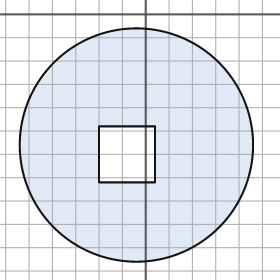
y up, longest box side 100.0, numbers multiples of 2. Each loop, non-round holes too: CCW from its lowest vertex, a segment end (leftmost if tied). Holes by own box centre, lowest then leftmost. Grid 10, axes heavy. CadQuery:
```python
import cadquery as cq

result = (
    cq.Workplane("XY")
    .moveTo(-4.0, -56.0)
    .circle(50.0)
    .moveTo(-20.0, -72.0)
    .lineTo(4.0, -72.0)
    .lineTo(4.0, -48.0)
    .lineTo(-20.0, -48.0)
    .close()
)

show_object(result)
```